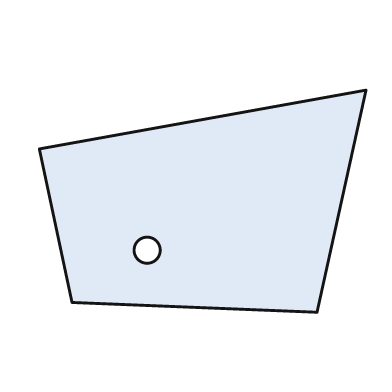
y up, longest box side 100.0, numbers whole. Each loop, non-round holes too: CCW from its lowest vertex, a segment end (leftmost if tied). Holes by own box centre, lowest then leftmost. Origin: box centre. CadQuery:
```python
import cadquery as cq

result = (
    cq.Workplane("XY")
    .moveTo(35.0, -34.0)
    .lineTo(50.0, 34.0)
    .lineTo(-50.0, 16.0)
    .lineTo(-40.0, -31.0)
    .close()
    .moveTo(-17.0, -15.0)
    .circle(4.0)
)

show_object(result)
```